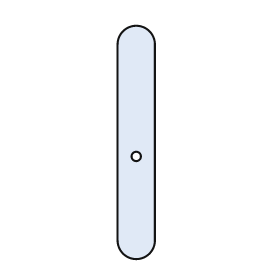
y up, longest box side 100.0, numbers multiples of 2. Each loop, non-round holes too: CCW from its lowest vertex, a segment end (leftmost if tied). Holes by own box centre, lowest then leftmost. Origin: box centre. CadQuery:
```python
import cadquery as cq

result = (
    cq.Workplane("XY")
    .moveTo(-8.0, -42.0)
    .threePointArc((0.0, -50.0), (8.0, -42.0))
    .lineTo(8.0, 42.0)
    .threePointArc((0.0, 50.0), (-8.0, 42.0))
    .close()
    .moveTo(0.0, -6.0)
    .circle(2.0)
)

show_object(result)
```